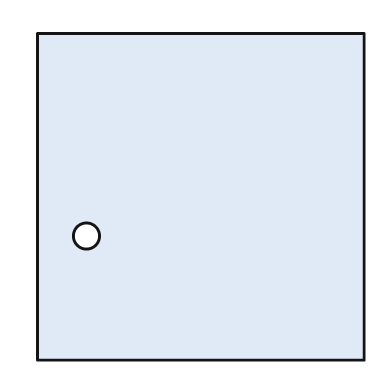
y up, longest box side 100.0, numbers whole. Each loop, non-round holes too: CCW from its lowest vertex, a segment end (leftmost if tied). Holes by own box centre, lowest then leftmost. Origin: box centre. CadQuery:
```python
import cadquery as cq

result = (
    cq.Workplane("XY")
    .moveTo(-50.0, -50.0)
    .lineTo(50.0, -50.0)
    .lineTo(50.0, 50.0)
    .lineTo(-50.0, 50.0)
    .close()
    .moveTo(-35.0, -12.0)
    .circle(4.0)
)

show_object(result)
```